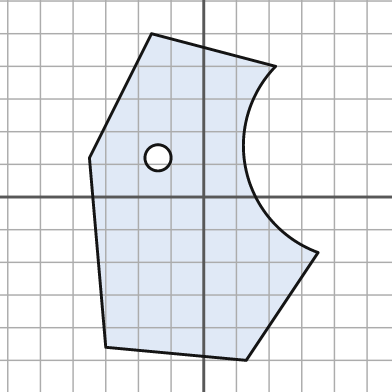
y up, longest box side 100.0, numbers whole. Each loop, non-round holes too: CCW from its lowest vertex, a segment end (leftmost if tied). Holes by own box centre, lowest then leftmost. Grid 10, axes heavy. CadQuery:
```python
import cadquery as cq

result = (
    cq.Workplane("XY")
    .moveTo(13.0, -50.0)
    .lineTo(35.0, -17.0)
    .threePointArc((13.0, 8.0), (22.0, 40.0))
    .lineTo(-16.0, 50.0)
    .lineTo(-35.0, 12.0)
    .lineTo(-30.0, -46.0)
    .close()
    .moveTo(-14.0, 12.0)
    .circle(4.0)
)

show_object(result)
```